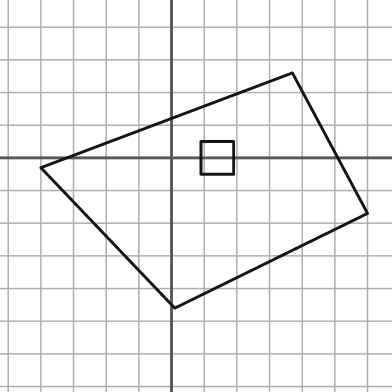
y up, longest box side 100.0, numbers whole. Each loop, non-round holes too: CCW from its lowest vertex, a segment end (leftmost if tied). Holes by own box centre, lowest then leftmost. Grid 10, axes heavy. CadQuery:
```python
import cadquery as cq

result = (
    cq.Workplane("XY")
    .moveTo(1.0, -46.0)
    .lineTo(60.0, -17.0)
    .lineTo(37.0, 26.0)
    .lineTo(-40.0, -3.0)
    .close()
    .moveTo(9.0, -5.0)
    .lineTo(19.0, -5.0)
    .lineTo(19.0, 5.0)
    .lineTo(9.0, 5.0)
    .close()
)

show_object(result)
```